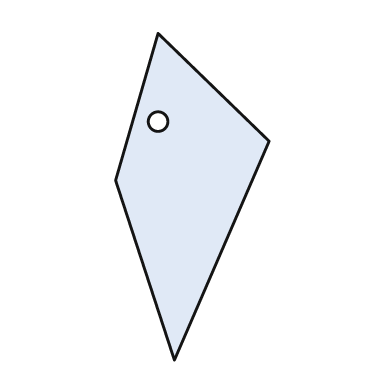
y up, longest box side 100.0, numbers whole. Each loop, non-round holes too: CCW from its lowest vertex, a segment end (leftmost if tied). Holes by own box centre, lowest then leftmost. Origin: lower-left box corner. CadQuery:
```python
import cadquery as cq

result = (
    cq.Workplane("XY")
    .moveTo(18.0, 0.0)
    .lineTo(47.0, 67.0)
    .lineTo(13.0, 100.0)
    .lineTo(0.0, 55.0)
    .close()
    .moveTo(13.0, 73.0)
    .circle(3.0)
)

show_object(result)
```